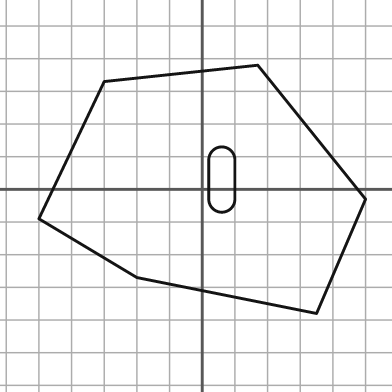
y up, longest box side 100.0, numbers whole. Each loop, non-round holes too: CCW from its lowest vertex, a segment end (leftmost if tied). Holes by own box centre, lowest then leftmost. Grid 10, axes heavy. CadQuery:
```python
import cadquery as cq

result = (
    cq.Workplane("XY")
    .moveTo(35.0, -38.0)
    .lineTo(50.0, -3.0)
    .lineTo(17.0, 38.0)
    .lineTo(-30.0, 33.0)
    .lineTo(-50.0, -9.0)
    .lineTo(-20.0, -27.0)
    .close()
    .moveTo(2.0, -3.0)
    .threePointArc((6.0, -7.0), (10.0, -3.0))
    .lineTo(10.0, 9.0)
    .threePointArc((6.0, 13.0), (2.0, 9.0))
    .close()
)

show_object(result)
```